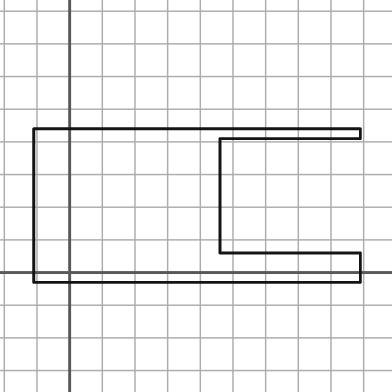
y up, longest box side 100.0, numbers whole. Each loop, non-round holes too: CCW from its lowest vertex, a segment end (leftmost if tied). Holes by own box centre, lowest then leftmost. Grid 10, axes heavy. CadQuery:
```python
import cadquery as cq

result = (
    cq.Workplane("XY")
    .moveTo(-11.0, -3.0)
    .lineTo(89.0, -3.0)
    .lineTo(89.0, 6.0)
    .lineTo(46.0, 6.0)
    .lineTo(46.0, 41.0)
    .lineTo(89.0, 41.0)
    .lineTo(89.0, 44.0)
    .lineTo(-11.0, 44.0)
    .close()
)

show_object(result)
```